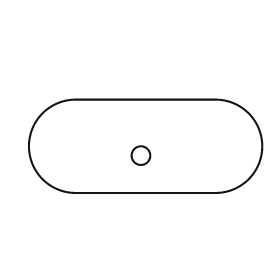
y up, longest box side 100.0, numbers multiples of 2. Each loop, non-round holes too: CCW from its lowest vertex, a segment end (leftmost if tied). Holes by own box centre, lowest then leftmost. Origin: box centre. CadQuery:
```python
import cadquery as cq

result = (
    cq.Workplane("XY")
    .moveTo(-30.0, -20.0)
    .lineTo(30.0, -20.0)
    .threePointArc((50.0, 0.0), (30.0, 20.0))
    .lineTo(-30.0, 20.0)
    .threePointArc((-50.0, 0.0), (-30.0, -20.0))
    .close()
    .moveTo(-2.0, -4.0)
    .circle(4.0)
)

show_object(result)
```